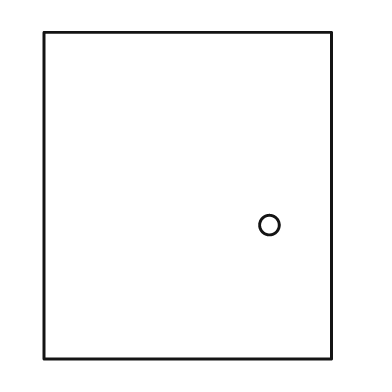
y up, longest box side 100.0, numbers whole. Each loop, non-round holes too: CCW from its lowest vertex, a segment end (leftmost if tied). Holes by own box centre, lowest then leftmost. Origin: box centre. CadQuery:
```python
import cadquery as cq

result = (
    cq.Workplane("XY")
    .moveTo(-44.0, -50.0)
    .lineTo(44.0, -50.0)
    .lineTo(44.0, 50.0)
    .lineTo(-44.0, 50.0)
    .close()
    .moveTo(25.0, -9.0)
    .circle(3.0)
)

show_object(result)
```